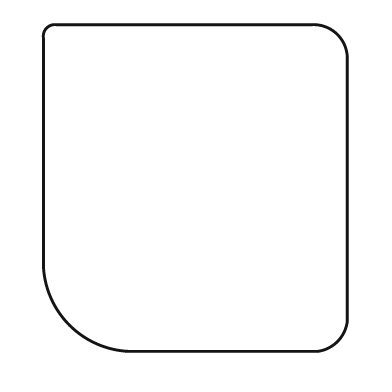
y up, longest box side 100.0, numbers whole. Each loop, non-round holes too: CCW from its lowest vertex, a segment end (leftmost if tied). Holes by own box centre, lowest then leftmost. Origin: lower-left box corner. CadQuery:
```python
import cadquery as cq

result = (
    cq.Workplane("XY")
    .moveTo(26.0, 0.0)
    .lineTo(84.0, 0.0)
    .threePointArc((90.0, 3.0), (93.0, 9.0))
    .lineTo(93.0, 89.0)
    .threePointArc((90.0, 97.0), (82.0, 100.0))
    .lineTo(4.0, 100.0)
    .threePointArc((1.0, 99.0), (0.0, 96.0))
    .lineTo(0.0, 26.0)
    .threePointArc((8.0, 8.0), (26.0, 0.0))
    .close()
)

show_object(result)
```